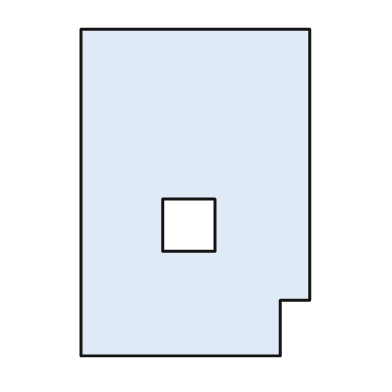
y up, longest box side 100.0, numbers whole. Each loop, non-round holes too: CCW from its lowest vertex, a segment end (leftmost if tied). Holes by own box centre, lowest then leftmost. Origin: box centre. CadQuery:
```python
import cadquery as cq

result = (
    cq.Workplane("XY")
    .moveTo(-35.0, -50.0)
    .lineTo(26.0, -50.0)
    .lineTo(26.0, -33.0)
    .lineTo(35.0, -33.0)
    .lineTo(35.0, 50.0)
    .lineTo(-35.0, 50.0)
    .close()
    .moveTo(-10.0, -18.0)
    .lineTo(6.0, -18.0)
    .lineTo(6.0, -2.0)
    .lineTo(-10.0, -2.0)
    .close()
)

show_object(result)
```